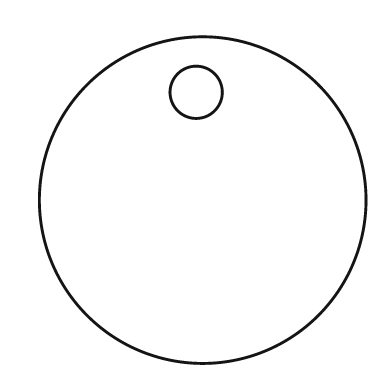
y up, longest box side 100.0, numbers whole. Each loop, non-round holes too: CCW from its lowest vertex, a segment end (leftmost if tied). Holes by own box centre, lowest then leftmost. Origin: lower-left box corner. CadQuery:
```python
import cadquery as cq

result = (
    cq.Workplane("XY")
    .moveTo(50.0, 50.0)
    .circle(50.0)
    .moveTo(48.0, 83.0)
    .circle(8.0)
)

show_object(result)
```